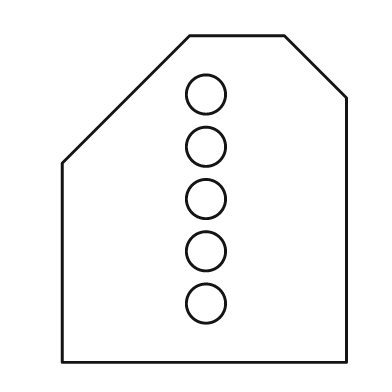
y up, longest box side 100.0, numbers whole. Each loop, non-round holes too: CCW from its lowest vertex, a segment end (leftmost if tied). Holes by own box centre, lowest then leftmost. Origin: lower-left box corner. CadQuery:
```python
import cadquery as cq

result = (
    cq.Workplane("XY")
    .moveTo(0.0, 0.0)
    .lineTo(87.0, 0.0)
    .lineTo(87.0, 81.0)
    .lineTo(68.0, 100.0)
    .lineTo(39.0, 100.0)
    .lineTo(0.0, 61.0)
    .close()
    .moveTo(44.0, 18.0)
    .circle(6.0)
    .moveTo(44.0, 34.0)
    .circle(6.0)
    .moveTo(44.0, 50.0)
    .circle(6.0)
    .moveTo(44.0, 66.0)
    .circle(6.0)
    .moveTo(44.0, 82.0)
    .circle(6.0)
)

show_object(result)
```